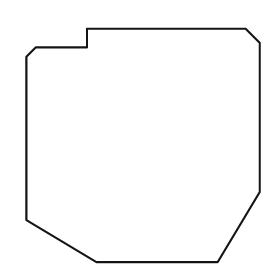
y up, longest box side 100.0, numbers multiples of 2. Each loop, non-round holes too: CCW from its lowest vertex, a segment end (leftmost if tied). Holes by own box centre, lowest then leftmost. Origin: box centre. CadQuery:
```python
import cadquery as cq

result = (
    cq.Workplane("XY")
    .moveTo(-20.0, -50.0)
    .lineTo(32.0, -50.0)
    .lineTo(50.0, -20.0)
    .lineTo(50.0, 44.0)
    .lineTo(44.0, 50.0)
    .lineTo(-24.0, 50.0)
    .lineTo(-24.0, 42.0)
    .lineTo(-46.0, 42.0)
    .lineTo(-50.0, 38.0)
    .lineTo(-50.0, -32.0)
    .close()
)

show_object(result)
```